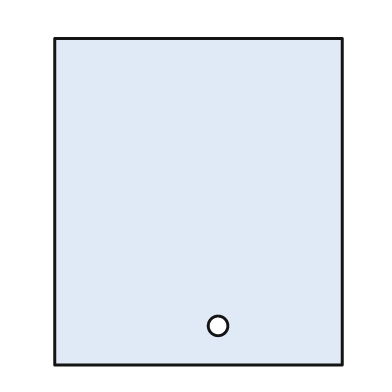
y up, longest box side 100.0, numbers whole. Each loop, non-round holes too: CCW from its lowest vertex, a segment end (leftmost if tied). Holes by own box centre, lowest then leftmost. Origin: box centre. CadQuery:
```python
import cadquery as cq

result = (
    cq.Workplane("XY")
    .moveTo(-44.0, -50.0)
    .lineTo(44.0, -50.0)
    .lineTo(44.0, 50.0)
    .lineTo(-44.0, 50.0)
    .close()
    .moveTo(6.0, -38.0)
    .circle(3.0)
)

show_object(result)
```